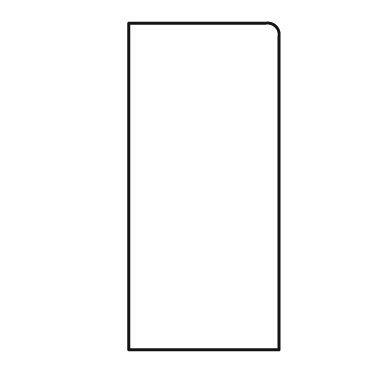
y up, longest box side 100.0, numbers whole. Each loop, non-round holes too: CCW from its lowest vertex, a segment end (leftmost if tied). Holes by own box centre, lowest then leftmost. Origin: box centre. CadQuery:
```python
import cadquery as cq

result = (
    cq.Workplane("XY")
    .moveTo(-23.0, -50.0)
    .lineTo(23.0, -50.0)
    .lineTo(23.0, 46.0)
    .threePointArc((22.0, 49.0), (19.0, 50.0))
    .lineTo(-23.0, 50.0)
    .close()
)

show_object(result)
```